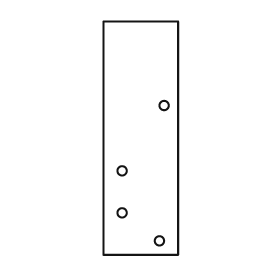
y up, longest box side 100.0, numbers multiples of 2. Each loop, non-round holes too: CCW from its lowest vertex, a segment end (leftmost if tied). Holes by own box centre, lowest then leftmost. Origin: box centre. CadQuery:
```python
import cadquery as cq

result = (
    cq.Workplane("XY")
    .moveTo(-16.0, -50.0)
    .lineTo(16.0, -50.0)
    .lineTo(16.0, 50.0)
    .lineTo(-16.0, 50.0)
    .close()
    .moveTo(8.0, -44.0)
    .circle(2.0)
    .moveTo(-8.0, -32.0)
    .circle(2.0)
    .moveTo(-8.0, -14.0)
    .circle(2.0)
    .moveTo(10.0, 14.0)
    .circle(2.0)
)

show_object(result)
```